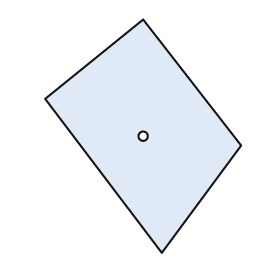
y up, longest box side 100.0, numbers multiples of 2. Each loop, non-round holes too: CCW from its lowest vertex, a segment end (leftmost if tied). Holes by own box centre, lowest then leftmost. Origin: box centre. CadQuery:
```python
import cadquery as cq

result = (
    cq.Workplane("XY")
    .moveTo(8.0, -50.0)
    .lineTo(42.0, -4.0)
    .lineTo(0.0, 50.0)
    .lineTo(-42.0, 16.0)
    .close()
    .moveTo(0.0, 0.0)
    .circle(2.0)
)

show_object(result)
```